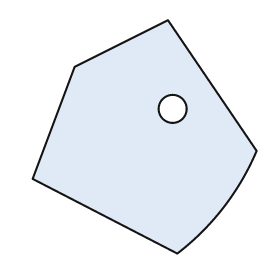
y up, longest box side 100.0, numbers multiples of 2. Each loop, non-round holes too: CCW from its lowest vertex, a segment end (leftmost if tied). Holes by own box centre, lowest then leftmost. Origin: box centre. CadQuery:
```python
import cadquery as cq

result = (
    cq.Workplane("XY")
    .moveTo(14.0, -50.0)
    .threePointArc((34.0, -30.0), (48.0, -6.0))
    .lineTo(10.0, 50.0)
    .lineTo(-30.0, 30.0)
    .lineTo(-48.0, -18.0)
    .close()
    .moveTo(12.0, 12.0)
    .circle(6.0)
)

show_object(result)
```